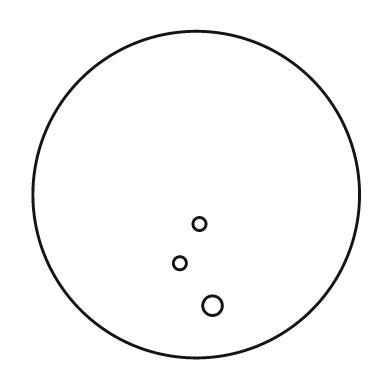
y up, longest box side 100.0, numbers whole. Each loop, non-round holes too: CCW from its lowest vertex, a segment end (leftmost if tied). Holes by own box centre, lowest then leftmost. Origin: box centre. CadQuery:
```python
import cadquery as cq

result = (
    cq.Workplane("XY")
    .moveTo(0.0, 0.0)
    .circle(50.0)
    .moveTo(5.0, -34.0)
    .circle(3.0)
    .moveTo(-5.0, -21.0)
    .circle(2.0)
    .moveTo(1.0, -9.0)
    .circle(2.0)
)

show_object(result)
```